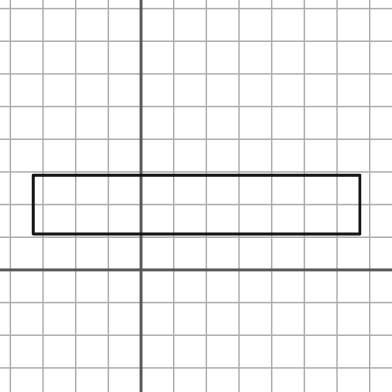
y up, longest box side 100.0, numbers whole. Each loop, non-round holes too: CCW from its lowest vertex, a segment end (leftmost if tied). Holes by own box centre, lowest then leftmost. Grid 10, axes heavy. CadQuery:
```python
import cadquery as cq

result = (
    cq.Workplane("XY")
    .moveTo(-33.0, 11.0)
    .lineTo(67.0, 11.0)
    .lineTo(67.0, 29.0)
    .lineTo(-33.0, 29.0)
    .close()
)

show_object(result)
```